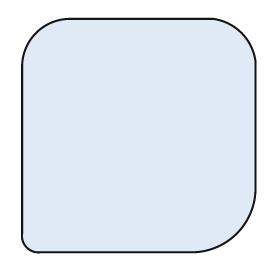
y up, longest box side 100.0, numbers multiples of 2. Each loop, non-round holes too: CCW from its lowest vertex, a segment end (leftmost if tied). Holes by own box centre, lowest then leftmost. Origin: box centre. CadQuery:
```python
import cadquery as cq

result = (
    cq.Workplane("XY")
    .moveTo(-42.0, -50.0)
    .lineTo(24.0, -50.0)
    .threePointArc((42.0, -42.0), (50.0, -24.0))
    .lineTo(50.0, 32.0)
    .threePointArc((44.0, 44.0), (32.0, 50.0))
    .lineTo(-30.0, 50.0)
    .threePointArc((-44.0, 44.0), (-50.0, 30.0))
    .lineTo(-50.0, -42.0)
    .threePointArc((-48.0, -48.0), (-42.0, -50.0))
    .close()
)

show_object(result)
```